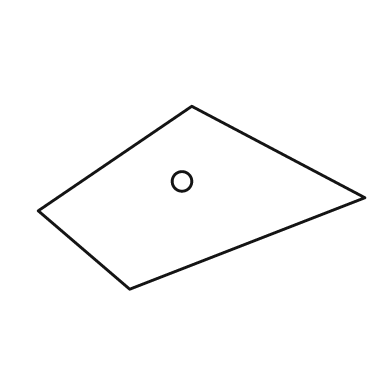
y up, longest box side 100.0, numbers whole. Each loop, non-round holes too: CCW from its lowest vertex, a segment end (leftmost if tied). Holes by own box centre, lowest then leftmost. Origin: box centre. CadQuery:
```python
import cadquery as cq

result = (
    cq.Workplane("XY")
    .moveTo(-22.0, -28.0)
    .lineTo(50.0, 0.0)
    .lineTo(-3.0, 28.0)
    .lineTo(-50.0, -4.0)
    .close()
    .moveTo(-6.0, 5.0)
    .circle(3.0)
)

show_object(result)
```